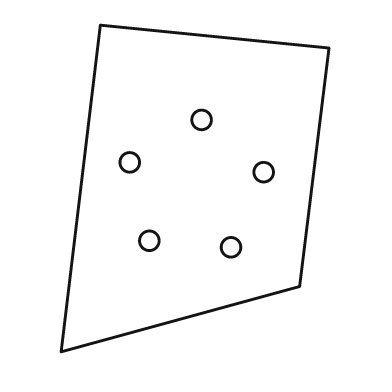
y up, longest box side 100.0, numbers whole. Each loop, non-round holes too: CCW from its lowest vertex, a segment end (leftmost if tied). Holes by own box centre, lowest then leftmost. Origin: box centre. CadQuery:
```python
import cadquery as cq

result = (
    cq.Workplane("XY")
    .moveTo(-41.0, -50.0)
    .lineTo(32.0, -30.0)
    .lineTo(41.0, 43.0)
    .lineTo(-29.0, 50.0)
    .close()
    .moveTo(11.0, -18.0)
    .circle(3.0)
    .moveTo(-14.0, -16.0)
    .circle(3.0)
    .moveTo(21.0, 5.0)
    .circle(3.0)
    .moveTo(-20.0, 8.0)
    .circle(3.0)
    .moveTo(2.0, 21.0)
    .circle(3.0)
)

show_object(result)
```